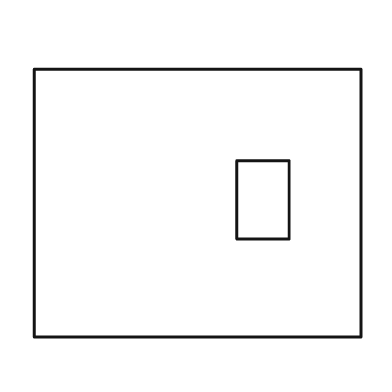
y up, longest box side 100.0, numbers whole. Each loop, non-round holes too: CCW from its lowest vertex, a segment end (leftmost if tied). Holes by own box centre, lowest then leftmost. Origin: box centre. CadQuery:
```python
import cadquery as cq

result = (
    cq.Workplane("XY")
    .moveTo(-50.0, -41.0)
    .lineTo(50.0, -41.0)
    .lineTo(50.0, 41.0)
    .lineTo(-50.0, 41.0)
    .close()
    .moveTo(12.0, -11.0)
    .lineTo(28.0, -11.0)
    .lineTo(28.0, 13.0)
    .lineTo(12.0, 13.0)
    .close()
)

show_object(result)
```